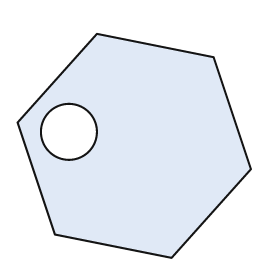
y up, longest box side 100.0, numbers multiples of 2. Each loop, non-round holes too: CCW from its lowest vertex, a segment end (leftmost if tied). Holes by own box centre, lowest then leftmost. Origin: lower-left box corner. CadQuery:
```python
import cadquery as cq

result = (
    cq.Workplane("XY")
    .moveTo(66.0, 0.0)
    .lineTo(100.0, 38.0)
    .lineTo(84.0, 86.0)
    .lineTo(34.0, 96.0)
    .lineTo(0.0, 58.0)
    .lineTo(16.0, 10.0)
    .close()
    .moveTo(22.0, 54.0)
    .circle(12.0)
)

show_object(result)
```